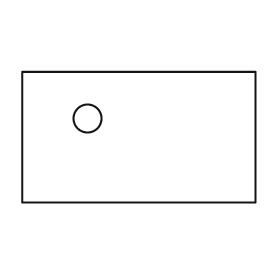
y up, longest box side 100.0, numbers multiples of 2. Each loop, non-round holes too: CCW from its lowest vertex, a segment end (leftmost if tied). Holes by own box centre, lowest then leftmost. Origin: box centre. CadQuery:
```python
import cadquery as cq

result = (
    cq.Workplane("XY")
    .moveTo(-50.0, -28.0)
    .lineTo(50.0, -28.0)
    .lineTo(50.0, 28.0)
    .lineTo(-50.0, 28.0)
    .close()
    .moveTo(-22.0, 8.0)
    .circle(6.0)
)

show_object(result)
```